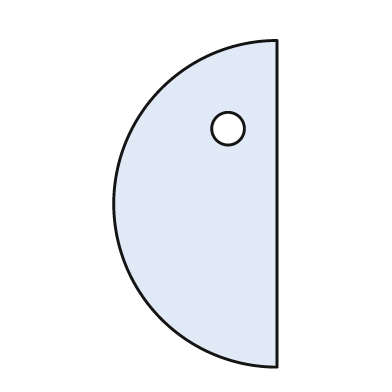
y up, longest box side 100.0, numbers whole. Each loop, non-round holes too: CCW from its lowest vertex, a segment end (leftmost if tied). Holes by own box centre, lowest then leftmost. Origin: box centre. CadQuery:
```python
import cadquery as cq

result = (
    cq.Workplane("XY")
    .moveTo(25.0, -50.0)
    .lineTo(25.0, 50.0)
    .threePointArc((-25.0, 0.0), (25.0, -50.0))
    .close()
    .moveTo(10.0, 23.0)
    .circle(5.0)
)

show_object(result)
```